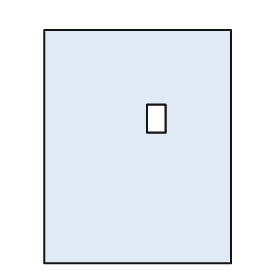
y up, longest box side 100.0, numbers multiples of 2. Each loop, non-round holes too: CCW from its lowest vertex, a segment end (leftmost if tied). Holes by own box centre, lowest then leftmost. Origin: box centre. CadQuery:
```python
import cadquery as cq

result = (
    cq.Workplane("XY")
    .moveTo(-40.0, -50.0)
    .lineTo(40.0, -50.0)
    .lineTo(40.0, 50.0)
    .lineTo(-40.0, 50.0)
    .close()
    .moveTo(4.0, 6.0)
    .lineTo(12.0, 6.0)
    .lineTo(12.0, 18.0)
    .lineTo(4.0, 18.0)
    .close()
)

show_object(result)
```